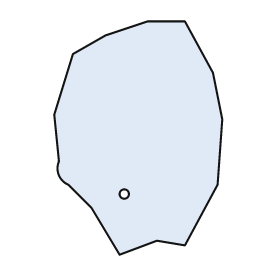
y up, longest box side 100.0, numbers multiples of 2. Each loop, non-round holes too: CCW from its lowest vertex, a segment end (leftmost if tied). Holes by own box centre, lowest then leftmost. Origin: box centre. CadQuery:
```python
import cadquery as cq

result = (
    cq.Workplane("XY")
    .moveTo(-8.0, -50.0)
    .lineTo(8.0, -44.0)
    .lineTo(20.0, -46.0)
    .lineTo(34.0, -20.0)
    .lineTo(36.0, 8.0)
    .lineTo(32.0, 28.0)
    .lineTo(20.0, 50.0)
    .lineTo(4.0, 50.0)
    .lineTo(-14.0, 44.0)
    .lineTo(-28.0, 36.0)
    .lineTo(-36.0, 10.0)
    .lineTo(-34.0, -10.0)
    .threePointArc((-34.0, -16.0), (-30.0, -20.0))
    .lineTo(-20.0, -30.0)
    .close()
    .moveTo(-6.0, -24.0)
    .circle(2.0)
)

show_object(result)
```